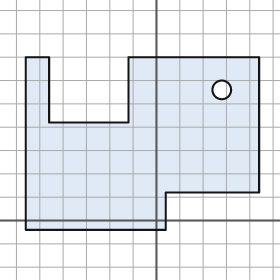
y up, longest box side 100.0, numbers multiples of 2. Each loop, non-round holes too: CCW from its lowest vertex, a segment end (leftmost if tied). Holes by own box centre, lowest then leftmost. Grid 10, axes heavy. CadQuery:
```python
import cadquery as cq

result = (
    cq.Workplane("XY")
    .moveTo(-56.0, -4.0)
    .lineTo(4.0, -4.0)
    .lineTo(4.0, 12.0)
    .lineTo(44.0, 12.0)
    .lineTo(44.0, 70.0)
    .lineTo(-12.0, 70.0)
    .lineTo(-12.0, 42.0)
    .lineTo(-46.0, 42.0)
    .lineTo(-46.0, 70.0)
    .lineTo(-56.0, 70.0)
    .close()
    .moveTo(28.0, 56.0)
    .circle(4.0)
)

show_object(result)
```